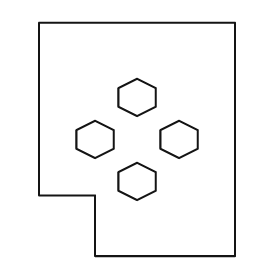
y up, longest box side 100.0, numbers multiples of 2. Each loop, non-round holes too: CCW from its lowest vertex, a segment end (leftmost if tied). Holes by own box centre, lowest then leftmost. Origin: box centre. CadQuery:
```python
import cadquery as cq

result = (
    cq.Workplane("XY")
    .moveTo(-18.0, -50.0)
    .lineTo(42.0, -50.0)
    .lineTo(42.0, 50.0)
    .lineTo(-42.0, 50.0)
    .lineTo(-42.0, -24.0)
    .lineTo(-18.0, -24.0)
    .close()
    .moveTo(0.0, -26.0)
    .lineTo(8.0, -22.0)
    .lineTo(8.0, -14.0)
    .lineTo(0.0, -10.0)
    .lineTo(-8.0, -14.0)
    .lineTo(-8.0, -22.0)
    .close()
    .moveTo(-18.0, -8.0)
    .lineTo(-10.0, -4.0)
    .lineTo(-10.0, 4.0)
    .lineTo(-18.0, 8.0)
    .lineTo(-26.0, 4.0)
    .lineTo(-26.0, -4.0)
    .close()
    .moveTo(18.0, -8.0)
    .lineTo(26.0, -4.0)
    .lineTo(26.0, 4.0)
    .lineTo(18.0, 8.0)
    .lineTo(10.0, 4.0)
    .lineTo(10.0, -4.0)
    .close()
    .moveTo(0.0, 10.0)
    .lineTo(8.0, 14.0)
    .lineTo(8.0, 22.0)
    .lineTo(0.0, 26.0)
    .lineTo(-8.0, 22.0)
    .lineTo(-8.0, 14.0)
    .close()
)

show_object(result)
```